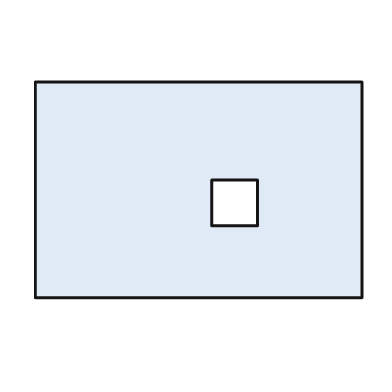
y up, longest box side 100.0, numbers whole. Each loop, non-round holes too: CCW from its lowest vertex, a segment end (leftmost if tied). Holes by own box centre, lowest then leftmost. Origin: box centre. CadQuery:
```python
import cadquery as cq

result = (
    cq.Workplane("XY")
    .moveTo(-50.0, -33.0)
    .lineTo(50.0, -33.0)
    .lineTo(50.0, 33.0)
    .lineTo(-50.0, 33.0)
    .close()
    .moveTo(4.0, -11.0)
    .lineTo(18.0, -11.0)
    .lineTo(18.0, 3.0)
    .lineTo(4.0, 3.0)
    .close()
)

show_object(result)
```